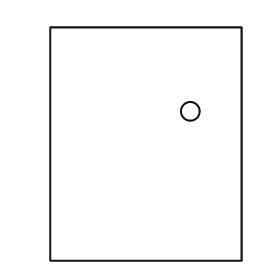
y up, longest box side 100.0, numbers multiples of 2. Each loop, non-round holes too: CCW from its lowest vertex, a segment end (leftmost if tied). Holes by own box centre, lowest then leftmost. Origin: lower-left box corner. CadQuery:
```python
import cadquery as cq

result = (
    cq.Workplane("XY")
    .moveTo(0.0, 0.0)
    .lineTo(82.0, 0.0)
    .lineTo(82.0, 100.0)
    .lineTo(0.0, 100.0)
    .close()
    .moveTo(60.0, 64.0)
    .circle(4.0)
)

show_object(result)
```